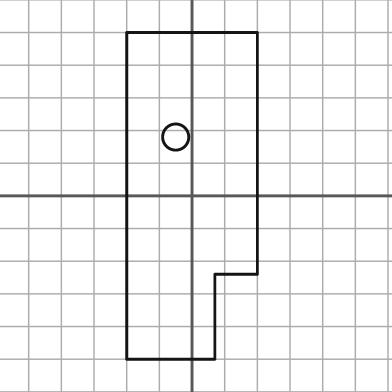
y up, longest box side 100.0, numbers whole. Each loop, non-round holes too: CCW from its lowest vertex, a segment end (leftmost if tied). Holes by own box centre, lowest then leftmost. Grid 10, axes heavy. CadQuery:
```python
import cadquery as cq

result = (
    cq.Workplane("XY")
    .moveTo(-20.0, -50.0)
    .lineTo(7.0, -50.0)
    .lineTo(7.0, -24.0)
    .lineTo(20.0, -24.0)
    .lineTo(20.0, 50.0)
    .lineTo(-20.0, 50.0)
    .close()
    .moveTo(-5.0, 18.0)
    .circle(4.0)
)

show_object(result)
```